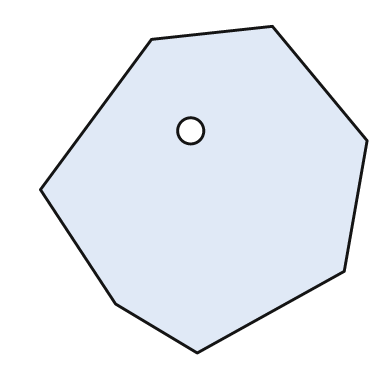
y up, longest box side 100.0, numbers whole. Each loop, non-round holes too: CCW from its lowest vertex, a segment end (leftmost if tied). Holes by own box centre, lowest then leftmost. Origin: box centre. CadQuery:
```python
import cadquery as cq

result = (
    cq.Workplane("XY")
    .moveTo(-2.0, -50.0)
    .lineTo(43.0, -25.0)
    .lineTo(50.0, 15.0)
    .lineTo(21.0, 50.0)
    .lineTo(-16.0, 46.0)
    .lineTo(-50.0, 0.0)
    .lineTo(-27.0, -35.0)
    .close()
    .moveTo(-4.0, 18.0)
    .circle(4.0)
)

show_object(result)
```